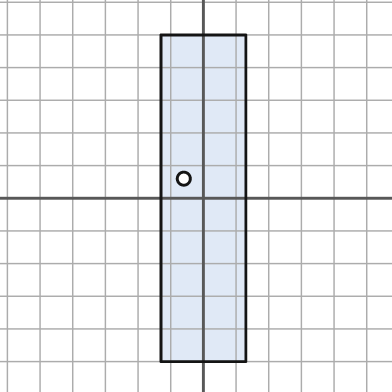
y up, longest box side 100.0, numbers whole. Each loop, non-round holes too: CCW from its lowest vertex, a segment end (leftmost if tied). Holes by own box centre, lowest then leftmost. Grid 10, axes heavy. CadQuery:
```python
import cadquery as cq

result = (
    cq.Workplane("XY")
    .moveTo(-13.0, -50.0)
    .lineTo(13.0, -50.0)
    .lineTo(13.0, 50.0)
    .lineTo(-13.0, 50.0)
    .close()
    .moveTo(-6.0, 6.0)
    .circle(2.0)
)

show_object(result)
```